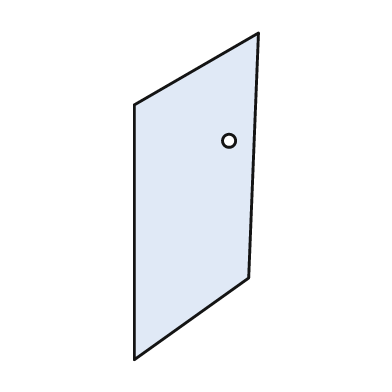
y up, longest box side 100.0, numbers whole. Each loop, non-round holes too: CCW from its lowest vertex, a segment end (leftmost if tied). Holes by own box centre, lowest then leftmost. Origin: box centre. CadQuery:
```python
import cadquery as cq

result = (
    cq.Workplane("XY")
    .moveTo(-19.0, -50.0)
    .lineTo(16.0, -25.0)
    .lineTo(19.0, 50.0)
    .lineTo(-19.0, 28.0)
    .close()
    .moveTo(10.0, 17.0)
    .circle(2.0)
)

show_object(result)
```